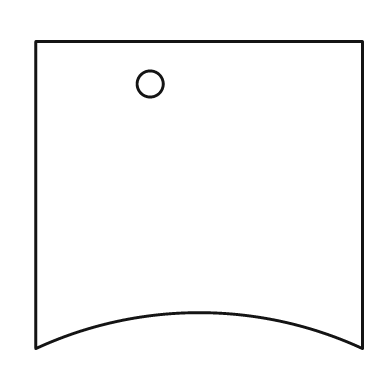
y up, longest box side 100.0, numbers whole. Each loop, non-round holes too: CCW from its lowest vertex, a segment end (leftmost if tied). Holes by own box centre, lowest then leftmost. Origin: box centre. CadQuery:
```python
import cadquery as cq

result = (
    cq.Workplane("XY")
    .moveTo(-50.0, -47.0)
    .threePointArc((0.0, -36.0), (50.0, -47.0))
    .lineTo(50.0, 47.0)
    .lineTo(-50.0, 47.0)
    .close()
    .moveTo(-15.0, 34.0)
    .circle(4.0)
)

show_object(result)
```